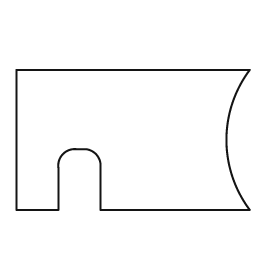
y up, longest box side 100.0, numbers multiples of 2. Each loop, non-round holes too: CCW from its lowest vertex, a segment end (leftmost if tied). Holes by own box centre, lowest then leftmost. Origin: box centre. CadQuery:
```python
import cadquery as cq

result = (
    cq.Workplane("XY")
    .moveTo(-50.0, -30.0)
    .lineTo(-32.0, -30.0)
    .lineTo(-32.0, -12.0)
    .threePointArc((-30.0, -6.0), (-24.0, -4.0))
    .lineTo(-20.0, -4.0)
    .threePointArc((-16.0, -6.0), (-14.0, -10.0))
    .lineTo(-14.0, -30.0)
    .lineTo(50.0, -30.0)
    .threePointArc((40.0, 0.0), (50.0, 30.0))
    .lineTo(-50.0, 30.0)
    .close()
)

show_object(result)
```